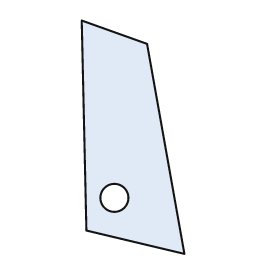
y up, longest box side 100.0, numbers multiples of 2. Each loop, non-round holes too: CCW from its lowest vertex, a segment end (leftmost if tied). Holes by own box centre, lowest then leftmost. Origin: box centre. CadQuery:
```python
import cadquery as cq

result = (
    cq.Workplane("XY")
    .moveTo(22.0, -50.0)
    .lineTo(6.0, 40.0)
    .lineTo(-22.0, 50.0)
    .lineTo(-20.0, -40.0)
    .close()
    .moveTo(-8.0, -26.0)
    .circle(6.0)
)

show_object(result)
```